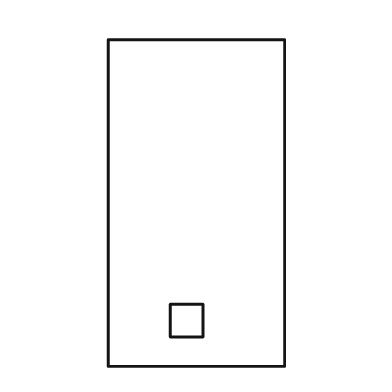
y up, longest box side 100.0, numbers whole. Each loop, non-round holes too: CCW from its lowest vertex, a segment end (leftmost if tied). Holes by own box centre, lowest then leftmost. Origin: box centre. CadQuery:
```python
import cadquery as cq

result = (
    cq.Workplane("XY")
    .moveTo(-27.0, -50.0)
    .lineTo(27.0, -50.0)
    .lineTo(27.0, 50.0)
    .lineTo(-27.0, 50.0)
    .close()
    .moveTo(-8.0, -41.0)
    .lineTo(2.0, -41.0)
    .lineTo(2.0, -31.0)
    .lineTo(-8.0, -31.0)
    .close()
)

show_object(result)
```